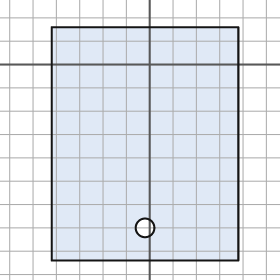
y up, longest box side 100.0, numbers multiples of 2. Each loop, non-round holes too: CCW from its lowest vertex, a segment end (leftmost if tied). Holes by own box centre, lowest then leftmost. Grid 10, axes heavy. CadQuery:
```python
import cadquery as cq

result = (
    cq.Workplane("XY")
    .moveTo(-42.0, -84.0)
    .lineTo(38.0, -84.0)
    .lineTo(38.0, 16.0)
    .lineTo(-42.0, 16.0)
    .close()
    .moveTo(-2.0, -70.0)
    .circle(4.0)
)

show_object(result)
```